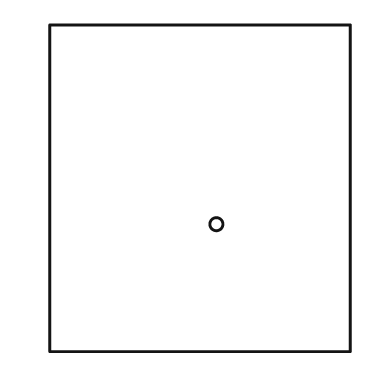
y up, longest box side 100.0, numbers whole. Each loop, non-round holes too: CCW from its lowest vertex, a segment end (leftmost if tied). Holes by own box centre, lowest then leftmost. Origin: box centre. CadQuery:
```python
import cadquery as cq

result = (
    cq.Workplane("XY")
    .moveTo(-46.0, -50.0)
    .lineTo(46.0, -50.0)
    .lineTo(46.0, 50.0)
    .lineTo(-46.0, 50.0)
    .close()
    .moveTo(5.0, -11.0)
    .circle(2.0)
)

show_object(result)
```